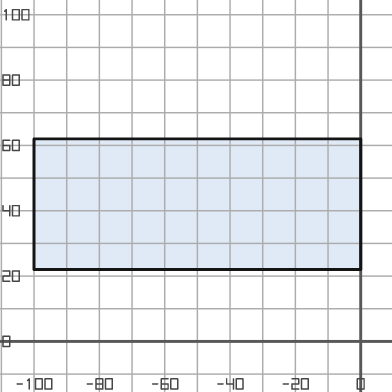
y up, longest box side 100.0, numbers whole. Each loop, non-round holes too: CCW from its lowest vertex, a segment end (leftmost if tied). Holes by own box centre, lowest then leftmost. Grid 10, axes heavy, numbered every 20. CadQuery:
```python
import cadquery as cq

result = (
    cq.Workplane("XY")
    .moveTo(-100.0, 22.0)
    .lineTo(0.0, 22.0)
    .lineTo(0.0, 62.0)
    .lineTo(-100.0, 62.0)
    .close()
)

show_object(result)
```